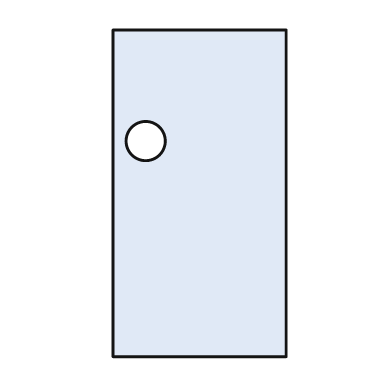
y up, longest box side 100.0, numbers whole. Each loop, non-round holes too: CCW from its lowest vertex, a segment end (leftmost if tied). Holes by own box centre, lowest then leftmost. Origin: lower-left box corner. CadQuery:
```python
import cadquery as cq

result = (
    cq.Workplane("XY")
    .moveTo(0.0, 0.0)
    .lineTo(53.0, 0.0)
    .lineTo(53.0, 100.0)
    .lineTo(0.0, 100.0)
    .close()
    .moveTo(10.0, 66.0)
    .circle(6.0)
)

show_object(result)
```